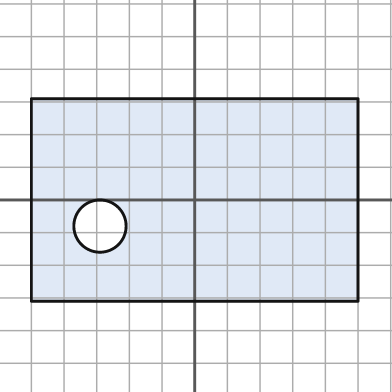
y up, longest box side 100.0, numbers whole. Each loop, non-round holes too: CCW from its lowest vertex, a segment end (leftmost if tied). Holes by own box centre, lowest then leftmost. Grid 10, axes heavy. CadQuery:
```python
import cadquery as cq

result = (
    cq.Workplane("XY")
    .moveTo(-50.0, -31.0)
    .lineTo(50.0, -31.0)
    .lineTo(50.0, 31.0)
    .lineTo(-50.0, 31.0)
    .close()
    .moveTo(-29.0, -8.0)
    .circle(8.0)
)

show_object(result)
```